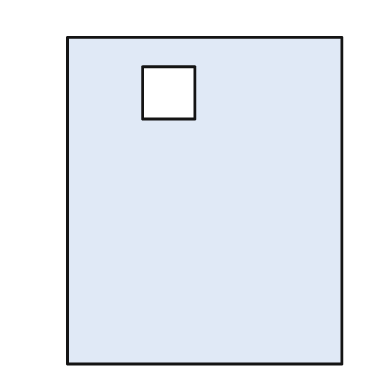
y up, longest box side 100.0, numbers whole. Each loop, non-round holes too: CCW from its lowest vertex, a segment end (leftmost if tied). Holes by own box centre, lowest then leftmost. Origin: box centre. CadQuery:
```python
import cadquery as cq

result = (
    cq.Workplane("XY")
    .moveTo(-42.0, -50.0)
    .lineTo(42.0, -50.0)
    .lineTo(42.0, 50.0)
    .lineTo(-42.0, 50.0)
    .close()
    .moveTo(-19.0, 25.0)
    .lineTo(-3.0, 25.0)
    .lineTo(-3.0, 41.0)
    .lineTo(-19.0, 41.0)
    .close()
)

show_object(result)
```